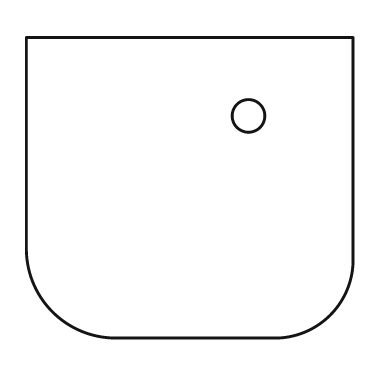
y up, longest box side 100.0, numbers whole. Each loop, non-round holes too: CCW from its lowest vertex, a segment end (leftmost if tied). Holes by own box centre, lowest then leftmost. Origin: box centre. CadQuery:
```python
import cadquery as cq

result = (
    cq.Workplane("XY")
    .moveTo(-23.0, -46.0)
    .lineTo(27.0, -46.0)
    .threePointArc((43.0, -39.0), (50.0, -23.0))
    .lineTo(50.0, 46.0)
    .lineTo(-50.0, 46.0)
    .lineTo(-50.0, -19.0)
    .threePointArc((-42.0, -38.0), (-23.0, -46.0))
    .close()
    .moveTo(18.0, 22.0)
    .circle(5.0)
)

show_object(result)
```